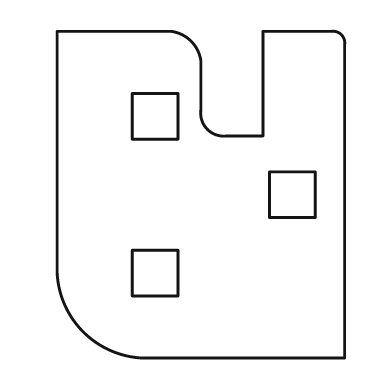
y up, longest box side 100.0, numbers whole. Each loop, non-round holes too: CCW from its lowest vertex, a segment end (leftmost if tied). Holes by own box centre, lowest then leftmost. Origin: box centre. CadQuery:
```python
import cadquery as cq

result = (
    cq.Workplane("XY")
    .moveTo(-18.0, -50.0)
    .lineTo(44.0, -50.0)
    .lineTo(44.0, 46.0)
    .threePointArc((43.0, 49.0), (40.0, 50.0))
    .lineTo(19.0, 50.0)
    .lineTo(19.0, 18.0)
    .lineTo(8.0, 18.0)
    .threePointArc((2.0, 20.0), (0.0, 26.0))
    .lineTo(0.0, 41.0)
    .threePointArc((-3.0, 47.0), (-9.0, 50.0))
    .lineTo(-44.0, 50.0)
    .lineTo(-44.0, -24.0)
    .threePointArc((-36.0, -42.0), (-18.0, -50.0))
    .close()
    .moveTo(-21.0, -31.0)
    .lineTo(-7.0, -31.0)
    .lineTo(-7.0, -17.0)
    .lineTo(-21.0, -17.0)
    .close()
    .moveTo(21.0, -7.0)
    .lineTo(35.0, -7.0)
    .lineTo(35.0, 7.0)
    .lineTo(21.0, 7.0)
    .close()
    .moveTo(-21.0, 17.0)
    .lineTo(-7.0, 17.0)
    .lineTo(-7.0, 31.0)
    .lineTo(-21.0, 31.0)
    .close()
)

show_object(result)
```